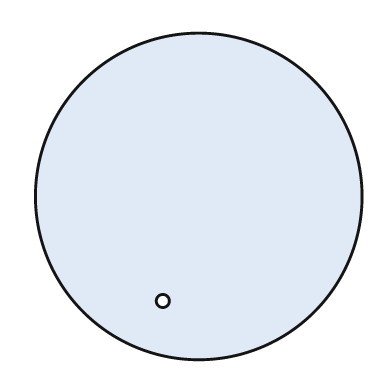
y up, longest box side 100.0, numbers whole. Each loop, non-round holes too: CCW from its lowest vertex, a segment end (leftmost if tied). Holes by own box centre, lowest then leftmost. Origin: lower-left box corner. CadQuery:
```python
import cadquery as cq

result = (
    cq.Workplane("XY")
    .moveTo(50.0, 50.0)
    .circle(50.0)
    .moveTo(39.0, 18.0)
    .circle(2.0)
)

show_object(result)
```